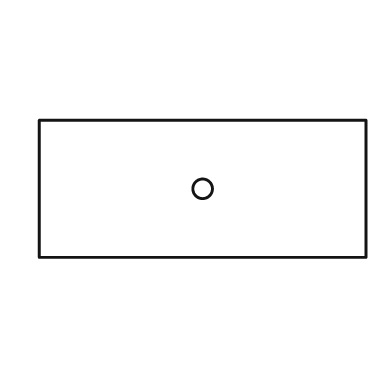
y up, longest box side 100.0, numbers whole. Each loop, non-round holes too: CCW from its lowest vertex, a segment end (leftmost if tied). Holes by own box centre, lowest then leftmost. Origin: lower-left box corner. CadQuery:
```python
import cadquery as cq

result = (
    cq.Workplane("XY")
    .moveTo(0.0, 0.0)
    .lineTo(100.0, 0.0)
    .lineTo(100.0, 42.0)
    .lineTo(0.0, 42.0)
    .close()
    .moveTo(50.0, 21.0)
    .circle(3.0)
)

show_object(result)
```